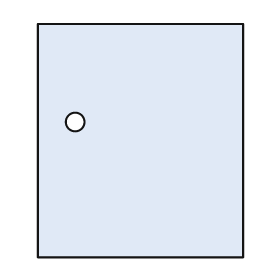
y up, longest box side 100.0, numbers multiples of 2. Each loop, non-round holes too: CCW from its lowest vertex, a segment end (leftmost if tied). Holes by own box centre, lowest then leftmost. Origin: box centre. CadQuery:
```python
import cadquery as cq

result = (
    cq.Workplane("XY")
    .moveTo(-44.0, -50.0)
    .lineTo(44.0, -50.0)
    .lineTo(44.0, 50.0)
    .lineTo(-44.0, 50.0)
    .close()
    .moveTo(-28.0, 8.0)
    .circle(4.0)
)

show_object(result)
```